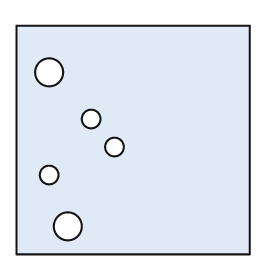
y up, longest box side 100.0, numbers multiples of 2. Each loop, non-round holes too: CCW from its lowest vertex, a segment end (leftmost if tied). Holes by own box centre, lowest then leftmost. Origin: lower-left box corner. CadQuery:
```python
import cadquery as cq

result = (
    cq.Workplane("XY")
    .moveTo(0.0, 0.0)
    .lineTo(100.0, 0.0)
    .lineTo(100.0, 98.0)
    .lineTo(0.0, 98.0)
    .close()
    .moveTo(22.0, 12.0)
    .circle(6.0)
    .moveTo(14.0, 34.0)
    .circle(4.0)
    .moveTo(42.0, 46.0)
    .circle(4.0)
    .moveTo(32.0, 58.0)
    .circle(4.0)
    .moveTo(14.0, 78.0)
    .circle(6.0)
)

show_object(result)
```